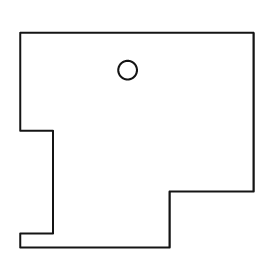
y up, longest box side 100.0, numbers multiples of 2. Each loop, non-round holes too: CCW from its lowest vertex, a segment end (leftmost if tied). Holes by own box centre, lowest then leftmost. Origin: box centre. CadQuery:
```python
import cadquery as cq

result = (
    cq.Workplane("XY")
    .moveTo(-50.0, -46.0)
    .lineTo(14.0, -46.0)
    .lineTo(14.0, -22.0)
    .lineTo(50.0, -22.0)
    .lineTo(50.0, 46.0)
    .lineTo(-50.0, 46.0)
    .lineTo(-50.0, 4.0)
    .lineTo(-36.0, 4.0)
    .lineTo(-36.0, -40.0)
    .lineTo(-50.0, -40.0)
    .close()
    .moveTo(-4.0, 30.0)
    .circle(4.0)
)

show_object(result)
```